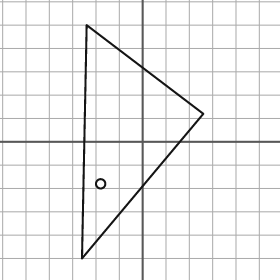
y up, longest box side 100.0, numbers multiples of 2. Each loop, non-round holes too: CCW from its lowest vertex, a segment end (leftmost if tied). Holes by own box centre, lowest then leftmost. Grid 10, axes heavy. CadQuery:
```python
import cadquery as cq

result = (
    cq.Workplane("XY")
    .moveTo(-26.0, -50.0)
    .lineTo(26.0, 12.0)
    .lineTo(-24.0, 50.0)
    .close()
    .moveTo(-18.0, -18.0)
    .circle(2.0)
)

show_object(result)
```